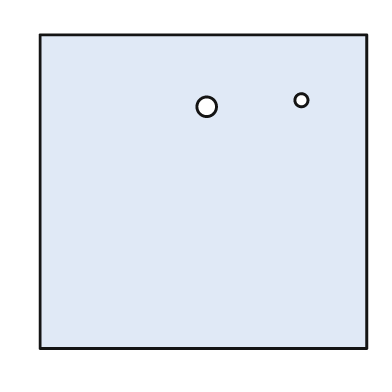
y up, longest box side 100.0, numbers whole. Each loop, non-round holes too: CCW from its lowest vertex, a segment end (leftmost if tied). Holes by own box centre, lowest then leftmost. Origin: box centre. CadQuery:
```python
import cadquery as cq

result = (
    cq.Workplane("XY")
    .moveTo(-50.0, -48.0)
    .lineTo(50.0, -48.0)
    .lineTo(50.0, 48.0)
    .lineTo(-50.0, 48.0)
    .close()
    .moveTo(1.0, 26.0)
    .circle(3.0)
    .moveTo(30.0, 28.0)
    .circle(2.0)
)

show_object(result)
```